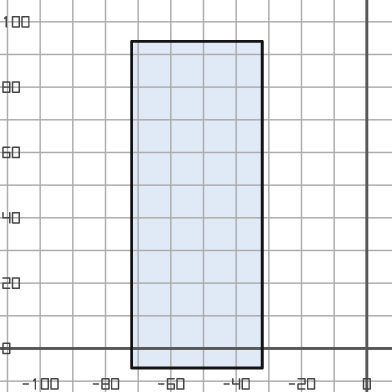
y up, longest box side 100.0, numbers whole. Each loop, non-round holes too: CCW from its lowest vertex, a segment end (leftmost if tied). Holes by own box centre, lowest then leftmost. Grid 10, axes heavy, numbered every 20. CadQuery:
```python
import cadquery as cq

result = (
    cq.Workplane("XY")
    .moveTo(-72.0, -6.0)
    .lineTo(-32.0, -6.0)
    .lineTo(-32.0, 94.0)
    .lineTo(-72.0, 94.0)
    .close()
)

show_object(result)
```